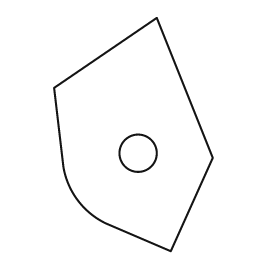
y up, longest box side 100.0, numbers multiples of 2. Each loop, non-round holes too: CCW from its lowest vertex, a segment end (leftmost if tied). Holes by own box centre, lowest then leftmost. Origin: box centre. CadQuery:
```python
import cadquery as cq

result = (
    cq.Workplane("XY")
    .moveTo(16.0, -50.0)
    .lineTo(34.0, -10.0)
    .lineTo(10.0, 50.0)
    .lineTo(-34.0, 20.0)
    .lineTo(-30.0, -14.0)
    .threePointArc((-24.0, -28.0), (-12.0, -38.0))
    .close()
    .moveTo(2.0, -8.0)
    .circle(8.0)
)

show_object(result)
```